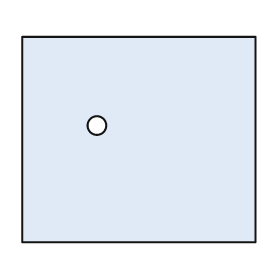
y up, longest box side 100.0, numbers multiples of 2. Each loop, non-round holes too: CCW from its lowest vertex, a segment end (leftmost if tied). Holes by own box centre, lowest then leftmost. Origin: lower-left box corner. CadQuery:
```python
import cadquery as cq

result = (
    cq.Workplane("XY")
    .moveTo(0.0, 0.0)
    .lineTo(100.0, 0.0)
    .lineTo(100.0, 88.0)
    .lineTo(0.0, 88.0)
    .close()
    .moveTo(32.0, 50.0)
    .circle(4.0)
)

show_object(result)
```